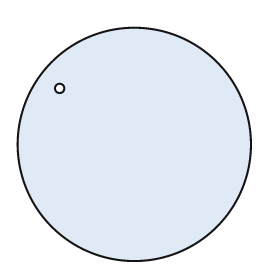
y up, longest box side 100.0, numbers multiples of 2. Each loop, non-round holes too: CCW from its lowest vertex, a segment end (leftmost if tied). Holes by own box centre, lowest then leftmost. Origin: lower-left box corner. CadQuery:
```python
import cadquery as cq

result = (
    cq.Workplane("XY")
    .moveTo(50.0, 50.0)
    .circle(50.0)
    .moveTo(18.0, 74.0)
    .circle(2.0)
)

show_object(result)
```